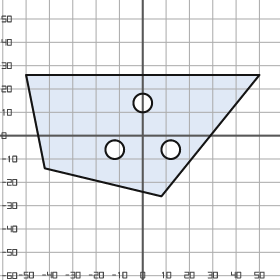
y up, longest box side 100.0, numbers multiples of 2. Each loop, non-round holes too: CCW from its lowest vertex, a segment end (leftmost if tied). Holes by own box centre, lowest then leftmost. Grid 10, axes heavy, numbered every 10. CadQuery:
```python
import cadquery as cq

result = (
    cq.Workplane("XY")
    .moveTo(8.0, -26.0)
    .lineTo(50.0, 26.0)
    .lineTo(-50.0, 26.0)
    .lineTo(-42.0, -14.0)
    .close()
    .moveTo(-12.0, -6.0)
    .circle(4.0)
    .moveTo(12.0, -6.0)
    .circle(4.0)
    .moveTo(0.0, 14.0)
    .circle(4.0)
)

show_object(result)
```